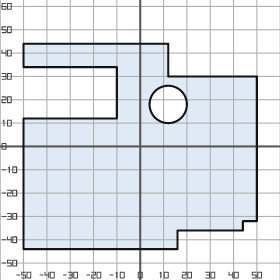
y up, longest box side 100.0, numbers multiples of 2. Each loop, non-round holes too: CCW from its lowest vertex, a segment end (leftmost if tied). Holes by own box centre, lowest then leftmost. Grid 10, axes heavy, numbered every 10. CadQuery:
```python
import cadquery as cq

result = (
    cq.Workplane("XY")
    .moveTo(-50.0, -44.0)
    .lineTo(16.0, -44.0)
    .lineTo(16.0, -36.0)
    .lineTo(44.0, -36.0)
    .lineTo(44.0, -32.0)
    .lineTo(50.0, -32.0)
    .lineTo(50.0, 30.0)
    .lineTo(12.0, 30.0)
    .lineTo(12.0, 44.0)
    .lineTo(-50.0, 44.0)
    .lineTo(-50.0, 34.0)
    .lineTo(-10.0, 34.0)
    .lineTo(-10.0, 12.0)
    .lineTo(-50.0, 12.0)
    .close()
    .moveTo(12.0, 18.0)
    .circle(8.0)
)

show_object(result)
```